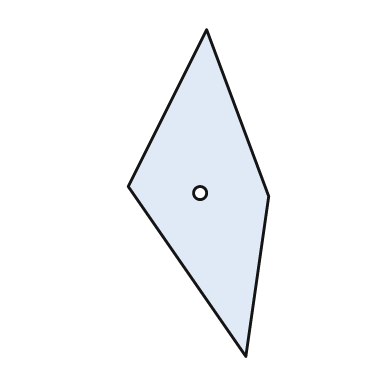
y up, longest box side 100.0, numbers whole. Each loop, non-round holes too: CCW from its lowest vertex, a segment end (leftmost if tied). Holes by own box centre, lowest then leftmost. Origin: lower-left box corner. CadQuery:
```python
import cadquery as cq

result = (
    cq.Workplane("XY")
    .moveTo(36.0, 0.0)
    .lineTo(43.0, 49.0)
    .lineTo(24.0, 100.0)
    .lineTo(0.0, 52.0)
    .close()
    .moveTo(22.0, 50.0)
    .circle(2.0)
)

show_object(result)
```